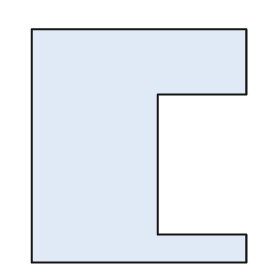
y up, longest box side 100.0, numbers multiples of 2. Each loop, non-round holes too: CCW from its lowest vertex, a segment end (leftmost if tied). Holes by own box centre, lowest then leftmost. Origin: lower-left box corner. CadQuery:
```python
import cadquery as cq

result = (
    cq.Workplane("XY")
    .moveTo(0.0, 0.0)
    .lineTo(92.0, 0.0)
    .lineTo(92.0, 12.0)
    .lineTo(54.0, 12.0)
    .lineTo(54.0, 72.0)
    .lineTo(92.0, 72.0)
    .lineTo(92.0, 100.0)
    .lineTo(0.0, 100.0)
    .close()
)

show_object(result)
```